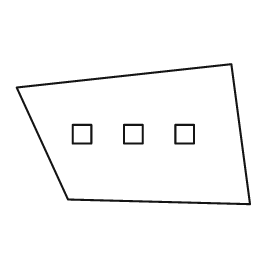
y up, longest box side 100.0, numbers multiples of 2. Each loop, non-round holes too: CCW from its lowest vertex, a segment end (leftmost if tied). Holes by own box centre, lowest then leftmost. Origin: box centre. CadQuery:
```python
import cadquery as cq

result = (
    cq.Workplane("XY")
    .moveTo(50.0, -30.0)
    .lineTo(42.0, 30.0)
    .lineTo(-50.0, 20.0)
    .lineTo(-28.0, -28.0)
    .close()
    .moveTo(-26.0, -4.0)
    .lineTo(-18.0, -4.0)
    .lineTo(-18.0, 4.0)
    .lineTo(-26.0, 4.0)
    .close()
    .moveTo(-4.0, -4.0)
    .lineTo(4.0, -4.0)
    .lineTo(4.0, 4.0)
    .lineTo(-4.0, 4.0)
    .close()
    .moveTo(18.0, -4.0)
    .lineTo(26.0, -4.0)
    .lineTo(26.0, 4.0)
    .lineTo(18.0, 4.0)
    .close()
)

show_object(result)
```